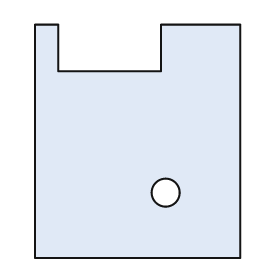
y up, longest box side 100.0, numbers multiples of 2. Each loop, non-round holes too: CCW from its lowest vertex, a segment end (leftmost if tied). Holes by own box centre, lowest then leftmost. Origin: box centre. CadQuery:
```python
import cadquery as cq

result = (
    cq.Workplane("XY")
    .moveTo(-44.0, -50.0)
    .lineTo(44.0, -50.0)
    .lineTo(44.0, 50.0)
    .lineTo(10.0, 50.0)
    .lineTo(10.0, 30.0)
    .lineTo(-34.0, 30.0)
    .lineTo(-34.0, 50.0)
    .lineTo(-44.0, 50.0)
    .close()
    .moveTo(12.0, -22.0)
    .circle(6.0)
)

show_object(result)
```